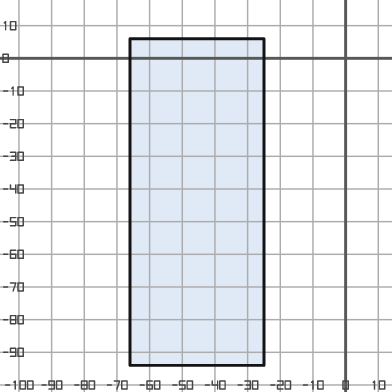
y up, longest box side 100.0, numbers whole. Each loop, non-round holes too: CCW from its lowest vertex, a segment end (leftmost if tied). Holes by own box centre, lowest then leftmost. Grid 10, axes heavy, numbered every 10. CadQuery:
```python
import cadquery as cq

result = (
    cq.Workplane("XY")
    .moveTo(-66.0, -94.0)
    .lineTo(-25.0, -94.0)
    .lineTo(-25.0, 6.0)
    .lineTo(-66.0, 6.0)
    .close()
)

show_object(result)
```